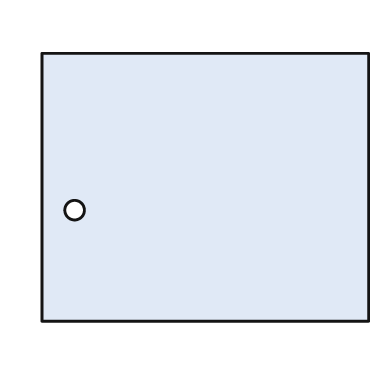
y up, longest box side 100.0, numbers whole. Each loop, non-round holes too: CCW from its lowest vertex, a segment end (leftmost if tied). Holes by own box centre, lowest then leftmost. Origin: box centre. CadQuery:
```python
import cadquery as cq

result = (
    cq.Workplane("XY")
    .moveTo(-50.0, -41.0)
    .lineTo(50.0, -41.0)
    .lineTo(50.0, 41.0)
    .lineTo(-50.0, 41.0)
    .close()
    .moveTo(-40.0, -7.0)
    .circle(3.0)
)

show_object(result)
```